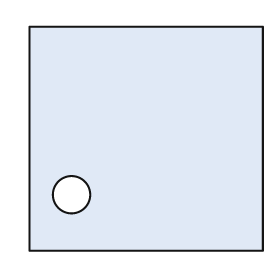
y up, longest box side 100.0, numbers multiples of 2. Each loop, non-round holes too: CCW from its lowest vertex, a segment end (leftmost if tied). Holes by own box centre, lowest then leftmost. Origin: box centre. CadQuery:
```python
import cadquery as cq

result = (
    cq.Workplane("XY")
    .moveTo(-50.0, -48.0)
    .lineTo(50.0, -48.0)
    .lineTo(50.0, 48.0)
    .lineTo(-50.0, 48.0)
    .close()
    .moveTo(-32.0, -24.0)
    .circle(8.0)
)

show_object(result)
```